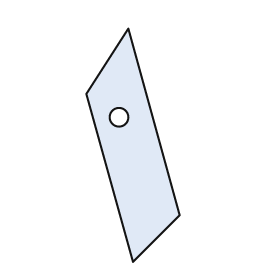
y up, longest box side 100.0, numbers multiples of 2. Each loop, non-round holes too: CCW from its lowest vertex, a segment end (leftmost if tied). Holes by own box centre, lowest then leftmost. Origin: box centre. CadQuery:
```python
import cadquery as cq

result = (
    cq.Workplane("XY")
    .moveTo(0.0, -50.0)
    .lineTo(20.0, -30.0)
    .lineTo(-2.0, 50.0)
    .lineTo(-20.0, 22.0)
    .close()
    .moveTo(-6.0, 12.0)
    .circle(4.0)
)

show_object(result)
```